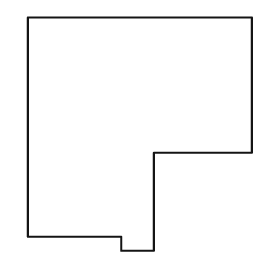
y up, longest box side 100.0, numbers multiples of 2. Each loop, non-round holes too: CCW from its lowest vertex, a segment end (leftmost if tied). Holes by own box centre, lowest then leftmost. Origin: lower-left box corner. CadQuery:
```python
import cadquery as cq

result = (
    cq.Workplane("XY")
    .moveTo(40.0, 0.0)
    .lineTo(54.0, 0.0)
    .lineTo(54.0, 42.0)
    .lineTo(96.0, 42.0)
    .lineTo(96.0, 100.0)
    .lineTo(0.0, 100.0)
    .lineTo(0.0, 6.0)
    .lineTo(40.0, 6.0)
    .close()
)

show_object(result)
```